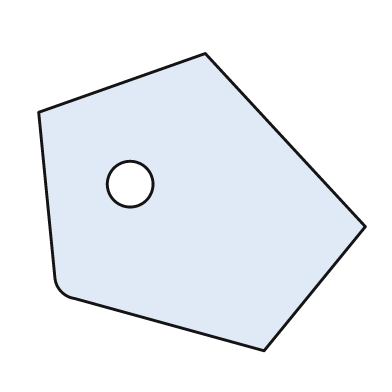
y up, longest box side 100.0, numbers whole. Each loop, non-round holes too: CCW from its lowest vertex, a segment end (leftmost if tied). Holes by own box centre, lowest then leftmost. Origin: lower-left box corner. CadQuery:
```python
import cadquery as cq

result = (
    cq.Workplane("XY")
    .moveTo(69.0, 0.0)
    .lineTo(100.0, 38.0)
    .lineTo(51.0, 91.0)
    .lineTo(0.0, 73.0)
    .lineTo(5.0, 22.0)
    .threePointArc((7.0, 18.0), (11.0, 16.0))
    .close()
    .moveTo(28.0, 51.0)
    .circle(7.0)
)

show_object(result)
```